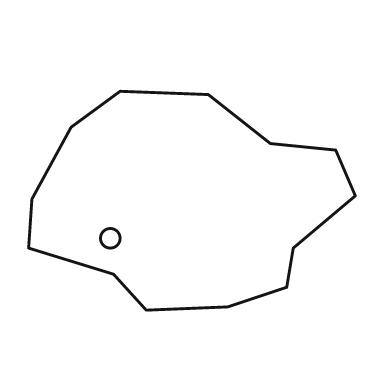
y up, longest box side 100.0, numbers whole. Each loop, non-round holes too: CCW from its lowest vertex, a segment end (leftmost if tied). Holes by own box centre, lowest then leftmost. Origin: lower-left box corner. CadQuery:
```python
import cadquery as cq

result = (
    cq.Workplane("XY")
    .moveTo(36.0, 0.0)
    .lineTo(61.0, 1.0)
    .lineTo(79.0, 7.0)
    .lineTo(81.0, 19.0)
    .lineTo(100.0, 35.0)
    .lineTo(94.0, 49.0)
    .lineTo(74.0, 51.0)
    .lineTo(55.0, 66.0)
    .lineTo(28.0, 67.0)
    .lineTo(13.0, 56.0)
    .lineTo(1.0, 34.0)
    .lineTo(0.0, 19.0)
    .lineTo(26.0, 11.0)
    .close()
    .moveTo(25.0, 22.0)
    .circle(3.0)
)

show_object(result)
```